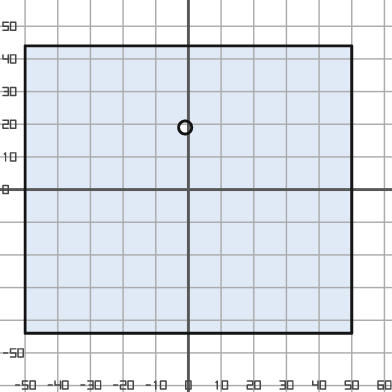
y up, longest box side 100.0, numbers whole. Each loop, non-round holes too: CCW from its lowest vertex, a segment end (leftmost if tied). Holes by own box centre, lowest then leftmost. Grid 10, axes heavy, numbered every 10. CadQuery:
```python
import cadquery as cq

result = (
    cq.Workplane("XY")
    .moveTo(-50.0, -44.0)
    .lineTo(50.0, -44.0)
    .lineTo(50.0, 44.0)
    .lineTo(-50.0, 44.0)
    .close()
    .moveTo(-1.0, 19.0)
    .circle(2.0)
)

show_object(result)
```